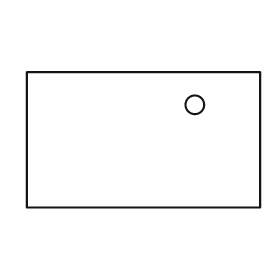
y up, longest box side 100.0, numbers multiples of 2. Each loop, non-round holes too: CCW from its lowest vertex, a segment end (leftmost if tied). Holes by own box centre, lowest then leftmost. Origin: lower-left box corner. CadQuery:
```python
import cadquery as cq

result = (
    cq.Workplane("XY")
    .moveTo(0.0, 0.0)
    .lineTo(100.0, 0.0)
    .lineTo(100.0, 58.0)
    .lineTo(0.0, 58.0)
    .close()
    .moveTo(72.0, 44.0)
    .circle(4.0)
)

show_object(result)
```